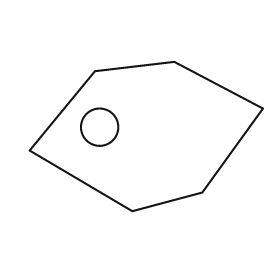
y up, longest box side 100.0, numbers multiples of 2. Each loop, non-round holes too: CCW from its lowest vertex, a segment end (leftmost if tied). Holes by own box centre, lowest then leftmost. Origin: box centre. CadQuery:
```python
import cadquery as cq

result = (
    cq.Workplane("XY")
    .moveTo(-6.0, -32.0)
    .lineTo(24.0, -24.0)
    .lineTo(50.0, 12.0)
    .lineTo(12.0, 32.0)
    .lineTo(-22.0, 28.0)
    .lineTo(-50.0, -6.0)
    .close()
    .moveTo(-20.0, 4.0)
    .circle(8.0)
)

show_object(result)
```